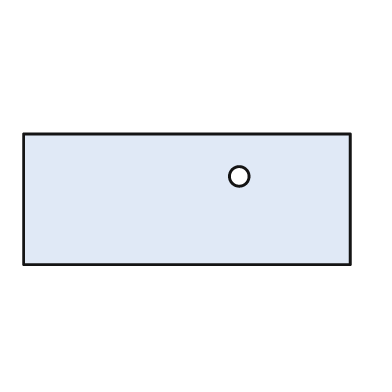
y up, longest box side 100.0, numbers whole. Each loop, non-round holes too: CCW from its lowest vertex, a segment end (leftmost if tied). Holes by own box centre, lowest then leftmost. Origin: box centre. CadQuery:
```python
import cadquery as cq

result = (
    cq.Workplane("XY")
    .moveTo(-50.0, -20.0)
    .lineTo(50.0, -20.0)
    .lineTo(50.0, 20.0)
    .lineTo(-50.0, 20.0)
    .close()
    .moveTo(16.0, 7.0)
    .circle(3.0)
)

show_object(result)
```